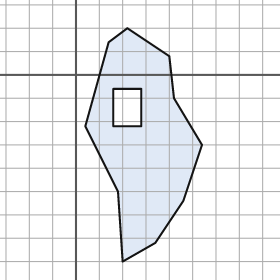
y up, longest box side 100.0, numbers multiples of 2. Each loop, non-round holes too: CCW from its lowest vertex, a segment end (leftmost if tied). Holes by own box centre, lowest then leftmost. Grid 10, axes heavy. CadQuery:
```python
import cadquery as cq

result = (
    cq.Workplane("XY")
    .moveTo(20.0, -80.0)
    .lineTo(34.0, -72.0)
    .lineTo(46.0, -54.0)
    .lineTo(54.0, -30.0)
    .lineTo(42.0, -10.0)
    .lineTo(40.0, 8.0)
    .lineTo(22.0, 20.0)
    .lineTo(14.0, 14.0)
    .lineTo(4.0, -22.0)
    .lineTo(18.0, -50.0)
    .close()
    .moveTo(16.0, -22.0)
    .lineTo(28.0, -22.0)
    .lineTo(28.0, -6.0)
    .lineTo(16.0, -6.0)
    .close()
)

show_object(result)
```